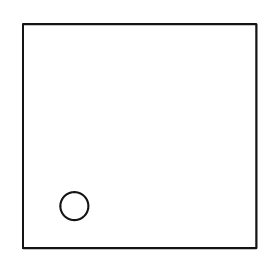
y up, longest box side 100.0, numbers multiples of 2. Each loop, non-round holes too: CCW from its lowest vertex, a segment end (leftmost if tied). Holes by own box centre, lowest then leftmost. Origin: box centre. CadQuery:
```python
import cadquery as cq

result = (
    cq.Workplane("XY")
    .moveTo(-50.0, -48.0)
    .lineTo(50.0, -48.0)
    .lineTo(50.0, 48.0)
    .lineTo(-50.0, 48.0)
    .close()
    .moveTo(-28.0, -30.0)
    .circle(6.0)
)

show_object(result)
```